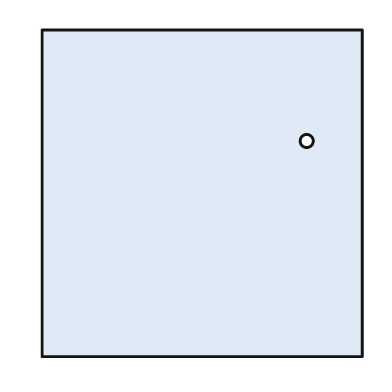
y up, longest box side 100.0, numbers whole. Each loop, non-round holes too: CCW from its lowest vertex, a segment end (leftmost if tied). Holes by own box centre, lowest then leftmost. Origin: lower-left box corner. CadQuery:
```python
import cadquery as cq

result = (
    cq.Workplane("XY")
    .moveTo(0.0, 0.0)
    .lineTo(98.0, 0.0)
    .lineTo(98.0, 100.0)
    .lineTo(0.0, 100.0)
    .close()
    .moveTo(81.0, 66.0)
    .circle(2.0)
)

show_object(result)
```